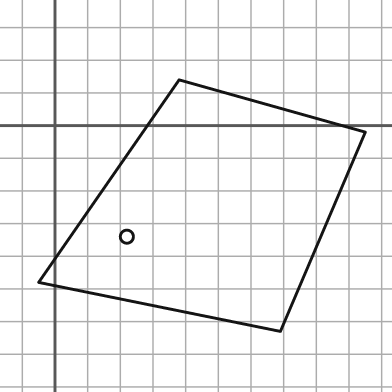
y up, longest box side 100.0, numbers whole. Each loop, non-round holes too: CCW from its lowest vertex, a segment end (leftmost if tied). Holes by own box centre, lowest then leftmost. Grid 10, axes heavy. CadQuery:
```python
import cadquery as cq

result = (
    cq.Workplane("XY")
    .moveTo(69.0, -63.0)
    .lineTo(95.0, -2.0)
    .lineTo(38.0, 14.0)
    .lineTo(-5.0, -48.0)
    .close()
    .moveTo(22.0, -34.0)
    .circle(2.0)
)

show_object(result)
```